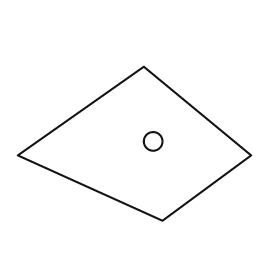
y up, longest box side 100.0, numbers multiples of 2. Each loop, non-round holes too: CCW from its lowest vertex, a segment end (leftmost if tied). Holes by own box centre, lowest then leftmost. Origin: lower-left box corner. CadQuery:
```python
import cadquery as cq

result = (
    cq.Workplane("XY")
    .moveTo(62.0, 0.0)
    .lineTo(100.0, 28.0)
    .lineTo(54.0, 66.0)
    .lineTo(0.0, 28.0)
    .close()
    .moveTo(58.0, 34.0)
    .circle(4.0)
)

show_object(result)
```